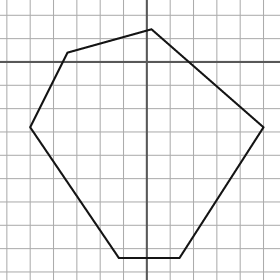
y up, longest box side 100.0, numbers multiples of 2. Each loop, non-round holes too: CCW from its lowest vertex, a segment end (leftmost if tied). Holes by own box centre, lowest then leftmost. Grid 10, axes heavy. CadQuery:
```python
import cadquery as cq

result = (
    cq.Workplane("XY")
    .moveTo(-12.0, -84.0)
    .lineTo(14.0, -84.0)
    .lineTo(50.0, -28.0)
    .lineTo(2.0, 14.0)
    .lineTo(-34.0, 4.0)
    .lineTo(-50.0, -28.0)
    .close()
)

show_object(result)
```